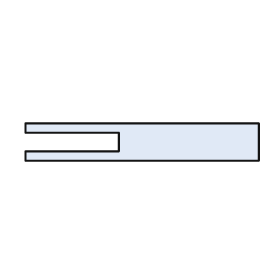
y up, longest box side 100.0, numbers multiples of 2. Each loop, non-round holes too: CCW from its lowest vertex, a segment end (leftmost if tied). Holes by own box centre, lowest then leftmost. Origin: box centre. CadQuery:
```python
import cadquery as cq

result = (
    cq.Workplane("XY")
    .moveTo(-50.0, -8.0)
    .lineTo(50.0, -8.0)
    .lineTo(50.0, 8.0)
    .lineTo(-50.0, 8.0)
    .lineTo(-50.0, 4.0)
    .lineTo(-10.0, 4.0)
    .lineTo(-10.0, -4.0)
    .lineTo(-50.0, -4.0)
    .close()
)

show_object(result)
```